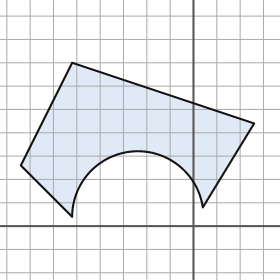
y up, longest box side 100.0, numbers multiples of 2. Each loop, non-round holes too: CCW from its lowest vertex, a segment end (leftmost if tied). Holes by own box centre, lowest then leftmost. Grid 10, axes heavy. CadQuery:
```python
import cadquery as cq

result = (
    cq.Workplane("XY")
    .moveTo(-52.0, 4.0)
    .threePointArc((-26.0, 32.0), (4.0, 8.0))
    .lineTo(26.0, 44.0)
    .lineTo(-52.0, 70.0)
    .lineTo(-74.0, 26.0)
    .close()
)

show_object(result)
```